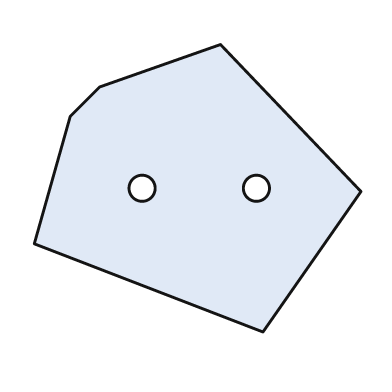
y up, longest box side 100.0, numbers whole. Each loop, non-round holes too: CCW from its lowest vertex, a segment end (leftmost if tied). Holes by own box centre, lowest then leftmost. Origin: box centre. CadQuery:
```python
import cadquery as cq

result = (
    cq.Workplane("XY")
    .moveTo(20.0, -44.0)
    .lineTo(50.0, -1.0)
    .lineTo(7.0, 44.0)
    .lineTo(-30.0, 31.0)
    .lineTo(-39.0, 22.0)
    .lineTo(-50.0, -17.0)
    .close()
    .moveTo(-17.0, 0.0)
    .circle(4.0)
    .moveTo(18.0, 0.0)
    .circle(4.0)
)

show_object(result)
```